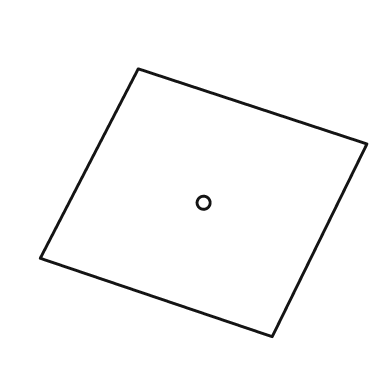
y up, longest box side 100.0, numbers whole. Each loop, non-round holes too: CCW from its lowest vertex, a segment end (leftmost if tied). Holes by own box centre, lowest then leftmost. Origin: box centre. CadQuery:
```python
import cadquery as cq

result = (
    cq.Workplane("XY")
    .moveTo(21.0, -41.0)
    .lineTo(50.0, 18.0)
    .lineTo(-20.0, 41.0)
    .lineTo(-50.0, -17.0)
    .close()
    .moveTo(0.0, 0.0)
    .circle(2.0)
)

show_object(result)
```